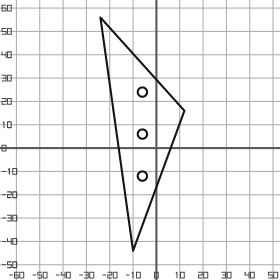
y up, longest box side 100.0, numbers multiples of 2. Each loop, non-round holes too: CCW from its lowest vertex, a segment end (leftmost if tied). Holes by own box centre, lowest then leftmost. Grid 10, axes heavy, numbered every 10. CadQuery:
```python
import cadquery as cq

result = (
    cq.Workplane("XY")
    .moveTo(-10.0, -44.0)
    .lineTo(12.0, 16.0)
    .lineTo(-24.0, 56.0)
    .close()
    .moveTo(-6.0, -12.0)
    .circle(2.0)
    .moveTo(-6.0, 6.0)
    .circle(2.0)
    .moveTo(-6.0, 24.0)
    .circle(2.0)
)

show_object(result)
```